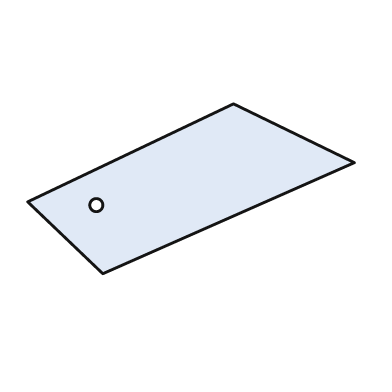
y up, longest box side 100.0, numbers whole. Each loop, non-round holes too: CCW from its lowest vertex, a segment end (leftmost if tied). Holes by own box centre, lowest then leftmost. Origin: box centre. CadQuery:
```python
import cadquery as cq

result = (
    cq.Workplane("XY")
    .moveTo(-27.0, -26.0)
    .lineTo(50.0, 8.0)
    .lineTo(13.0, 26.0)
    .lineTo(-50.0, -4.0)
    .close()
    .moveTo(-29.0, -5.0)
    .circle(2.0)
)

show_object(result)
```